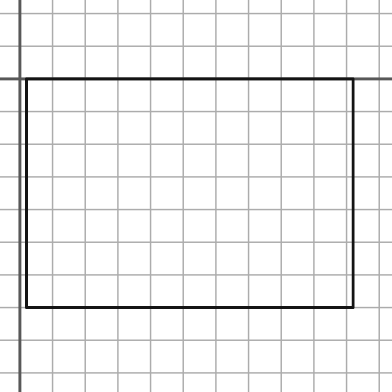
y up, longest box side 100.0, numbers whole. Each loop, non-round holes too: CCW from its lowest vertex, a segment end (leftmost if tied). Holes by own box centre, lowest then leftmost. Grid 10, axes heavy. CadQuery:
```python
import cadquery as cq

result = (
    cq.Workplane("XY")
    .moveTo(2.0, -70.0)
    .lineTo(102.0, -70.0)
    .lineTo(102.0, 0.0)
    .lineTo(2.0, 0.0)
    .close()
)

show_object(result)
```